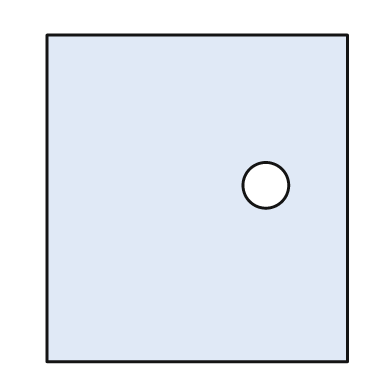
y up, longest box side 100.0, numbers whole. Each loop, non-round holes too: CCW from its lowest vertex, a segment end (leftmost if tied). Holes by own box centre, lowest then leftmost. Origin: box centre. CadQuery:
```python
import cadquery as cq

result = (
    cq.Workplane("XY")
    .moveTo(-46.0, -50.0)
    .lineTo(46.0, -50.0)
    .lineTo(46.0, 50.0)
    .lineTo(-46.0, 50.0)
    .close()
    .moveTo(21.0, 4.0)
    .circle(7.0)
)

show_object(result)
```